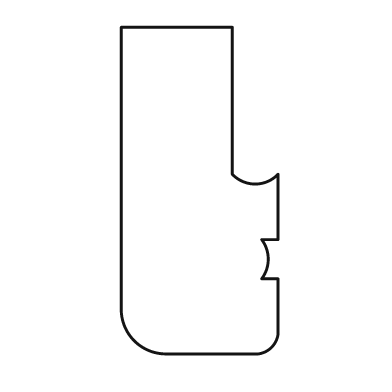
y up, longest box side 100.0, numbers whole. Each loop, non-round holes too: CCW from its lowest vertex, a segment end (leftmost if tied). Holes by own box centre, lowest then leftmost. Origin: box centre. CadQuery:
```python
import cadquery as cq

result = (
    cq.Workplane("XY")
    .moveTo(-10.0, -50.0)
    .lineTo(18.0, -50.0)
    .threePointArc((22.0, -48.0), (24.0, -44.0))
    .lineTo(24.0, -27.0)
    .lineTo(19.0, -27.0)
    .threePointArc((21.0, -21.0), (19.0, -15.0))
    .lineTo(24.0, -15.0)
    .lineTo(24.0, 5.0)
    .threePointArc((17.0, 2.0), (10.0, 5.0))
    .lineTo(10.0, 50.0)
    .lineTo(-24.0, 50.0)
    .lineTo(-24.0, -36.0)
    .threePointArc((-20.0, -46.0), (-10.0, -50.0))
    .close()
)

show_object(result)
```